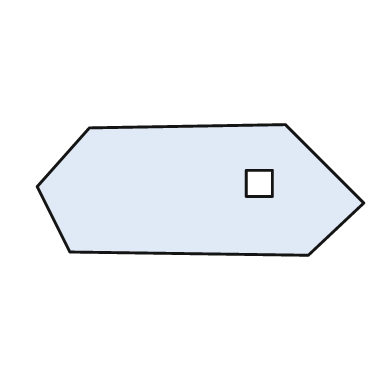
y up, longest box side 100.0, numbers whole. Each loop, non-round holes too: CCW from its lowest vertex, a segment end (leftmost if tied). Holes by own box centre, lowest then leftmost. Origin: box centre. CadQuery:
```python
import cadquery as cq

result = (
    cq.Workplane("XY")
    .moveTo(33.0, -20.0)
    .lineTo(50.0, -4.0)
    .lineTo(26.0, 20.0)
    .lineTo(-34.0, 19.0)
    .lineTo(-50.0, 1.0)
    .lineTo(-40.0, -19.0)
    .close()
    .moveTo(14.0, -2.0)
    .lineTo(22.0, -2.0)
    .lineTo(22.0, 6.0)
    .lineTo(14.0, 6.0)
    .close()
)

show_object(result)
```